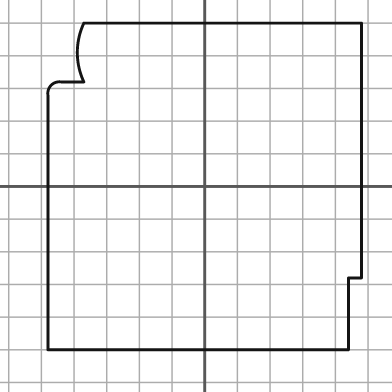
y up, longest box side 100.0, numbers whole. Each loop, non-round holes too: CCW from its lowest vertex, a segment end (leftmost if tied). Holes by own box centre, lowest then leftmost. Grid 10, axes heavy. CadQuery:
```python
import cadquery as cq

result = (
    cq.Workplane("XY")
    .moveTo(-48.0, -50.0)
    .lineTo(44.0, -50.0)
    .lineTo(44.0, -28.0)
    .lineTo(48.0, -28.0)
    .lineTo(48.0, 50.0)
    .lineTo(-37.0, 50.0)
    .threePointArc((-39.0, 41.0), (-37.0, 32.0))
    .lineTo(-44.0, 32.0)
    .threePointArc((-47.0, 31.0), (-48.0, 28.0))
    .close()
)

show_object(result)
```